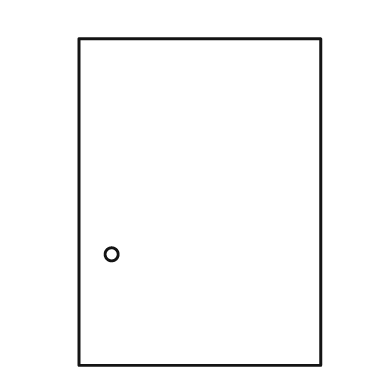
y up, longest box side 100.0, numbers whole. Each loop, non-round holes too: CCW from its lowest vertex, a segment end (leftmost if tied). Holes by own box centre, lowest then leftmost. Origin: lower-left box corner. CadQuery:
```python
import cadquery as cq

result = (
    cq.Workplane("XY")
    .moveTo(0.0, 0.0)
    .lineTo(74.0, 0.0)
    .lineTo(74.0, 100.0)
    .lineTo(0.0, 100.0)
    .close()
    .moveTo(10.0, 34.0)
    .circle(2.0)
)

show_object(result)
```